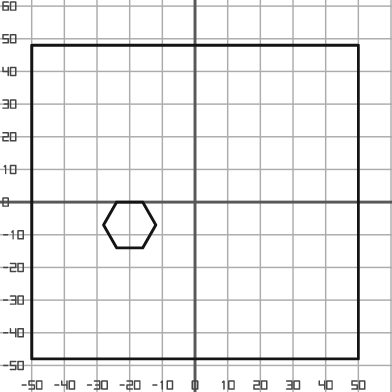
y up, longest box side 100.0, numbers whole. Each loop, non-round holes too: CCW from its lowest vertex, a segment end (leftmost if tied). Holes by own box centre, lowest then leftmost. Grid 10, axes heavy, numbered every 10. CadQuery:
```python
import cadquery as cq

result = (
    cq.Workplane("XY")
    .moveTo(-50.0, -48.0)
    .lineTo(50.0, -48.0)
    .lineTo(50.0, 48.0)
    .lineTo(-50.0, 48.0)
    .close()
    .moveTo(-24.0, -14.0)
    .lineTo(-16.0, -14.0)
    .lineTo(-12.0, -7.0)
    .lineTo(-16.0, 0.0)
    .lineTo(-24.0, 0.0)
    .lineTo(-28.0, -7.0)
    .close()
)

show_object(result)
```